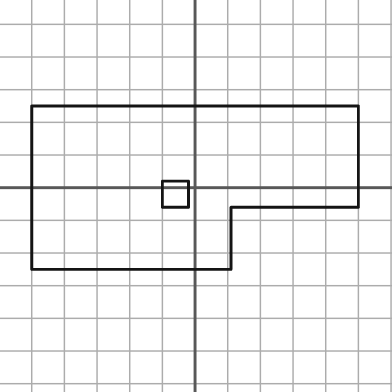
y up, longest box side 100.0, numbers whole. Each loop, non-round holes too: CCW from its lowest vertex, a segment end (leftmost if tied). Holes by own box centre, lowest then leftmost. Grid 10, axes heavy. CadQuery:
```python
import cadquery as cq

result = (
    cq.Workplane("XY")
    .moveTo(-50.0, -25.0)
    .lineTo(11.0, -25.0)
    .lineTo(11.0, -6.0)
    .lineTo(50.0, -6.0)
    .lineTo(50.0, 25.0)
    .lineTo(-50.0, 25.0)
    .close()
    .moveTo(-10.0, -6.0)
    .lineTo(-2.0, -6.0)
    .lineTo(-2.0, 2.0)
    .lineTo(-10.0, 2.0)
    .close()
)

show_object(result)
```